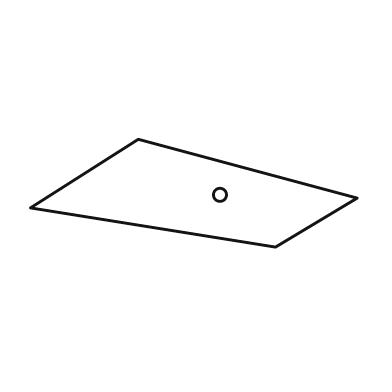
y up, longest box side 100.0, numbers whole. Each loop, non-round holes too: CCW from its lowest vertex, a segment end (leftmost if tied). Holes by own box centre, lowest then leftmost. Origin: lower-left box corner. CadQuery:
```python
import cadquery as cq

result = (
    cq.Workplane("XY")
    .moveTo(75.0, 0.0)
    .lineTo(100.0, 15.0)
    .lineTo(33.0, 33.0)
    .lineTo(0.0, 12.0)
    .close()
    .moveTo(58.0, 16.0)
    .circle(2.0)
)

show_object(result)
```